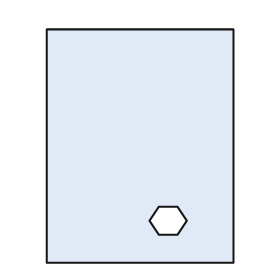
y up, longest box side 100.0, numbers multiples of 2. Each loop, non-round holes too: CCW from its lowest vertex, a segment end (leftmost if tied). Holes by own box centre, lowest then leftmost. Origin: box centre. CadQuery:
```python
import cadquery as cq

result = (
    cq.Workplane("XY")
    .moveTo(-40.0, -50.0)
    .lineTo(40.0, -50.0)
    .lineTo(40.0, 50.0)
    .lineTo(-40.0, 50.0)
    .close()
    .moveTo(8.0, -38.0)
    .lineTo(16.0, -38.0)
    .lineTo(20.0, -32.0)
    .lineTo(16.0, -26.0)
    .lineTo(8.0, -26.0)
    .lineTo(4.0, -32.0)
    .close()
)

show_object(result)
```